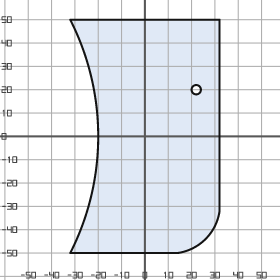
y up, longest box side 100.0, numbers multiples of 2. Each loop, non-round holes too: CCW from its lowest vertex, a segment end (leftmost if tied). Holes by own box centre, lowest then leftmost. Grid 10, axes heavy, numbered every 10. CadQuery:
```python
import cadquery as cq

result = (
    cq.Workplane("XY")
    .moveTo(-32.0, -50.0)
    .lineTo(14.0, -50.0)
    .threePointArc((26.0, -44.0), (32.0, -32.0))
    .lineTo(32.0, 50.0)
    .lineTo(-32.0, 50.0)
    .threePointArc((-20.0, 0.0), (-32.0, -50.0))
    .close()
    .moveTo(22.0, 20.0)
    .circle(2.0)
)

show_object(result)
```